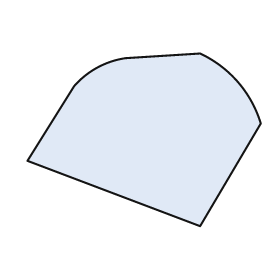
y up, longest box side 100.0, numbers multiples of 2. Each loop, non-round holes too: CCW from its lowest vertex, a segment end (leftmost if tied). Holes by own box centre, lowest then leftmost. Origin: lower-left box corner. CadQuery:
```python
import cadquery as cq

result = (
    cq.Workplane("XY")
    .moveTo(74.0, 0.0)
    .lineTo(100.0, 44.0)
    .threePointArc((90.0, 62.0), (74.0, 74.0))
    .lineTo(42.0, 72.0)
    .threePointArc((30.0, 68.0), (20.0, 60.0))
    .lineTo(0.0, 28.0)
    .close()
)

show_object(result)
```